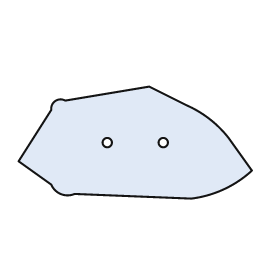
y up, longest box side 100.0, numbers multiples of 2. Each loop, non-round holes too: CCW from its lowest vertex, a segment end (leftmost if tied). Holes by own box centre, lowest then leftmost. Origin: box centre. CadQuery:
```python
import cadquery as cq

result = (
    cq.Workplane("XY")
    .moveTo(24.0, -24.0)
    .threePointArc((38.0, -20.0), (50.0, -12.0))
    .lineTo(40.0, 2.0)
    .threePointArc((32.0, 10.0), (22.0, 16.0))
    .lineTo(6.0, 24.0)
    .lineTo(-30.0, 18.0)
    .threePointArc((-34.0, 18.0), (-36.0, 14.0))
    .lineTo(-50.0, -8.0)
    .lineTo(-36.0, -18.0)
    .threePointArc((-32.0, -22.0), (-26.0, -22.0))
    .close()
    .moveTo(-12.0, 0.0)
    .circle(2.0)
    .moveTo(12.0, 0.0)
    .circle(2.0)
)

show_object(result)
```